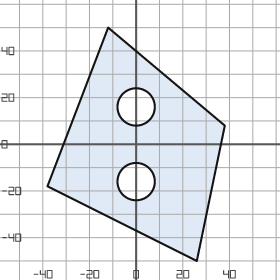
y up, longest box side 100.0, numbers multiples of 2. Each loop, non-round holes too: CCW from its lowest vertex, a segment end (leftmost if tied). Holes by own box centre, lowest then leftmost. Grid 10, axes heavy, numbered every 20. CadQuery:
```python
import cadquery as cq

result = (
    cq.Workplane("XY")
    .moveTo(26.0, -50.0)
    .lineTo(38.0, 8.0)
    .lineTo(-12.0, 50.0)
    .lineTo(-38.0, -18.0)
    .close()
    .moveTo(0.0, -16.0)
    .circle(8.0)
    .moveTo(0.0, 16.0)
    .circle(8.0)
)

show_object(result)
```